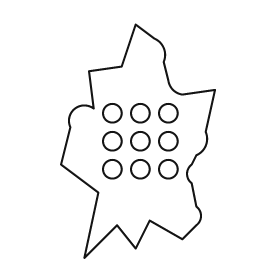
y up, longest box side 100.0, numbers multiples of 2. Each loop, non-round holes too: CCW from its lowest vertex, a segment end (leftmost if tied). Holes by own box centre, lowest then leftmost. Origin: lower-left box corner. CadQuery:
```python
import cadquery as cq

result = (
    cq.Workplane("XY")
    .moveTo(10.0, 0.0)
    .lineTo(24.0, 14.0)
    .lineTo(32.0, 4.0)
    .lineTo(38.0, 16.0)
    .lineTo(52.0, 8.0)
    .lineTo(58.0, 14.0)
    .threePointArc((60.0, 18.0), (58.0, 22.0))
    .lineTo(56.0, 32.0)
    .threePointArc((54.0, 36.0), (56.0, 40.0))
    .lineTo(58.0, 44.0)
    .threePointArc((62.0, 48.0), (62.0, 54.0))
    .lineTo(66.0, 72.0)
    .lineTo(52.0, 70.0)
    .threePointArc((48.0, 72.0), (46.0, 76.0))
    .lineTo(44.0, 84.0)
    .threePointArc((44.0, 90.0), (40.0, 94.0))
    .lineTo(32.0, 100.0)
    .lineTo(26.0, 82.0)
    .lineTo(12.0, 80.0)
    .lineTo(14.0, 64.0)
    .threePointArc((6.0, 64.0), (4.0, 56.0))
    .lineTo(0.0, 40.0)
    .lineTo(16.0, 28.0)
    .close()
    .moveTo(22.0, 38.0)
    .circle(4.0)
    .moveTo(34.0, 38.0)
    .circle(4.0)
    .moveTo(46.0, 38.0)
    .circle(4.0)
    .moveTo(22.0, 50.0)
    .circle(4.0)
    .moveTo(34.0, 50.0)
    .circle(4.0)
    .moveTo(46.0, 50.0)
    .circle(4.0)
    .moveTo(22.0, 62.0)
    .circle(4.0)
    .moveTo(34.0, 62.0)
    .circle(4.0)
    .moveTo(46.0, 62.0)
    .circle(4.0)
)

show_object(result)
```